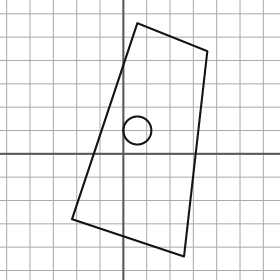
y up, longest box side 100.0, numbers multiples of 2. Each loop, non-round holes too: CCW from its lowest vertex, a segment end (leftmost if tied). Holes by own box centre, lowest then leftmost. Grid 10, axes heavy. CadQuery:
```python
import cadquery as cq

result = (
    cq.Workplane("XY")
    .moveTo(26.0, -44.0)
    .lineTo(36.0, 44.0)
    .lineTo(6.0, 56.0)
    .lineTo(-22.0, -28.0)
    .close()
    .moveTo(6.0, 10.0)
    .circle(6.0)
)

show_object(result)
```